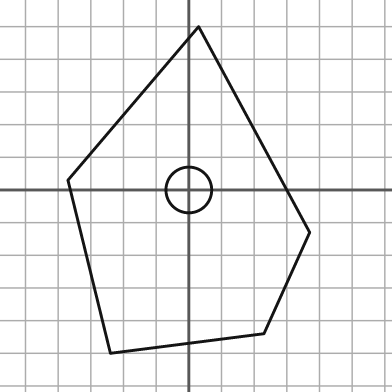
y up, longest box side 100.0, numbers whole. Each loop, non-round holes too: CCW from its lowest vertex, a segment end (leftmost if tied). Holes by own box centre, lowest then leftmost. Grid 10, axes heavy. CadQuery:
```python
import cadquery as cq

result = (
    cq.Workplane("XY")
    .moveTo(-24.0, -50.0)
    .lineTo(23.0, -44.0)
    .lineTo(37.0, -13.0)
    .lineTo(3.0, 50.0)
    .lineTo(-37.0, 3.0)
    .close()
    .moveTo(0.0, 0.0)
    .circle(7.0)
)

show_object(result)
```